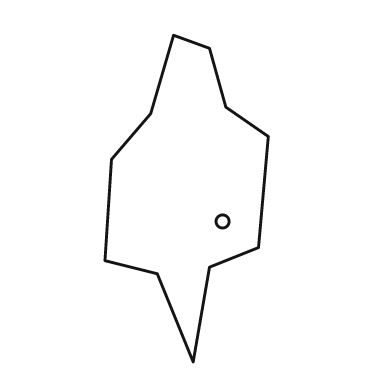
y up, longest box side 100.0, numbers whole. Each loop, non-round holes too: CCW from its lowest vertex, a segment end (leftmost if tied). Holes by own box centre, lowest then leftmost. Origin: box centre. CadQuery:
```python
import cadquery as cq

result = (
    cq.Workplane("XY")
    .moveTo(2.0, -50.0)
    .lineTo(7.0, -21.0)
    .lineTo(22.0, -15.0)
    .lineTo(25.0, 19.0)
    .lineTo(12.0, 28.0)
    .lineTo(7.0, 46.0)
    .lineTo(-4.0, 50.0)
    .lineTo(-11.0, 26.0)
    .lineTo(-23.0, 12.0)
    .lineTo(-25.0, -19.0)
    .lineTo(-9.0, -23.0)
    .close()
    .moveTo(11.0, -7.0)
    .circle(2.0)
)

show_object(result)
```